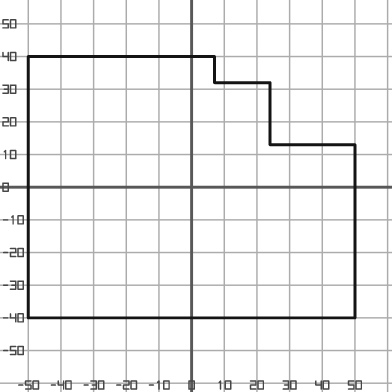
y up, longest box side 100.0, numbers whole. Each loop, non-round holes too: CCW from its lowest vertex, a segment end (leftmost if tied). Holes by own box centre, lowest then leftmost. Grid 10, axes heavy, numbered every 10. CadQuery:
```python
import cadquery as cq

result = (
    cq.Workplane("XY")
    .moveTo(-50.0, -40.0)
    .lineTo(50.0, -40.0)
    .lineTo(50.0, 13.0)
    .lineTo(24.0, 13.0)
    .lineTo(24.0, 32.0)
    .lineTo(7.0, 32.0)
    .lineTo(7.0, 40.0)
    .lineTo(-50.0, 40.0)
    .close()
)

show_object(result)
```